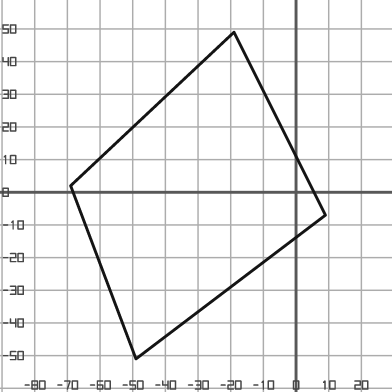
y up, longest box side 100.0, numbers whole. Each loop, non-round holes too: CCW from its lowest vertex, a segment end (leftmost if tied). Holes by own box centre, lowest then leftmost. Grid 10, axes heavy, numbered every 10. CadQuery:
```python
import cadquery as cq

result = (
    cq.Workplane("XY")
    .moveTo(-49.0, -51.0)
    .lineTo(9.0, -7.0)
    .lineTo(-19.0, 49.0)
    .lineTo(-69.0, 2.0)
    .close()
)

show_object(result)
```